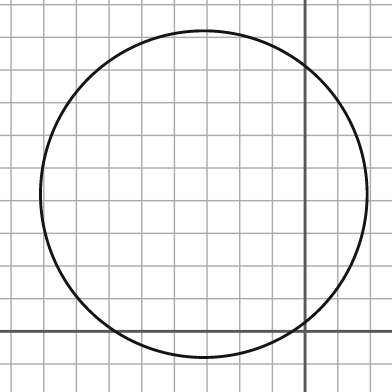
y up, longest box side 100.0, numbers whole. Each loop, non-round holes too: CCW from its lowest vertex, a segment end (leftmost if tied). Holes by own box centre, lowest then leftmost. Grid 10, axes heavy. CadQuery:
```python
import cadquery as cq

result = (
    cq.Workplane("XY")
    .moveTo(-31.0, 42.0)
    .circle(50.0)
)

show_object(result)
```